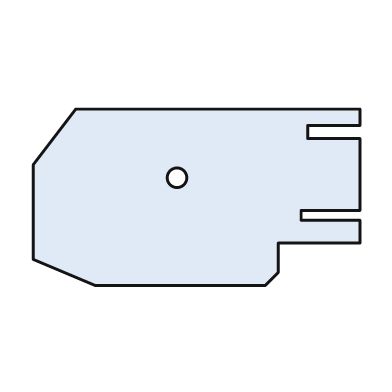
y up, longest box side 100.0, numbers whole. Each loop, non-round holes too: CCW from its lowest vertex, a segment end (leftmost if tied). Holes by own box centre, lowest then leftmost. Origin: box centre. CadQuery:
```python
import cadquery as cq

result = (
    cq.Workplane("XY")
    .moveTo(-31.0, -27.0)
    .lineTo(21.0, -27.0)
    .lineTo(25.0, -23.0)
    .lineTo(25.0, -14.0)
    .lineTo(50.0, -14.0)
    .lineTo(50.0, -7.0)
    .lineTo(32.0, -7.0)
    .lineTo(32.0, -4.0)
    .lineTo(50.0, -4.0)
    .lineTo(50.0, 18.0)
    .lineTo(34.0, 18.0)
    .lineTo(34.0, 22.0)
    .lineTo(50.0, 22.0)
    .lineTo(50.0, 27.0)
    .lineTo(-37.0, 27.0)
    .lineTo(-50.0, 10.0)
    .lineTo(-50.0, -19.0)
    .close()
    .moveTo(-6.0, 6.0)
    .circle(3.0)
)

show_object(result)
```